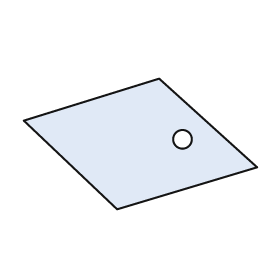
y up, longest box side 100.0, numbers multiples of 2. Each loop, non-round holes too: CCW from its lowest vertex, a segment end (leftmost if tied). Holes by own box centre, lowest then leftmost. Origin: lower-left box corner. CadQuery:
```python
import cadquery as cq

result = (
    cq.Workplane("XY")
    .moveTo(40.0, 0.0)
    .lineTo(100.0, 18.0)
    .lineTo(58.0, 56.0)
    .lineTo(0.0, 38.0)
    .close()
    .moveTo(68.0, 30.0)
    .circle(4.0)
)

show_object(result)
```